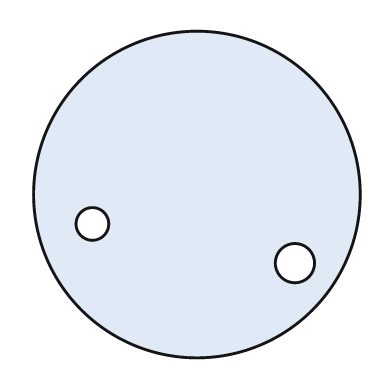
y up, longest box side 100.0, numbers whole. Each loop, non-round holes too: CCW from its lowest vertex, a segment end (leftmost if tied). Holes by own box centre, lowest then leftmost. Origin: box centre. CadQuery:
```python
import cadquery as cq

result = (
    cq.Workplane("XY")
    .moveTo(0.0, 0.0)
    .circle(50.0)
    .moveTo(30.0, -21.0)
    .circle(6.0)
    .moveTo(-32.0, -9.0)
    .circle(5.0)
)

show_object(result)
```